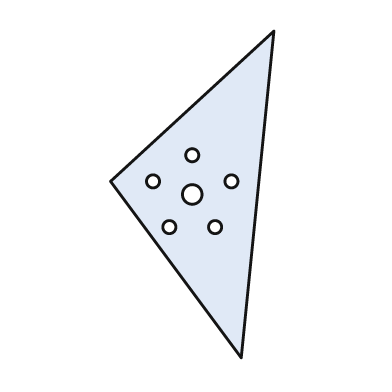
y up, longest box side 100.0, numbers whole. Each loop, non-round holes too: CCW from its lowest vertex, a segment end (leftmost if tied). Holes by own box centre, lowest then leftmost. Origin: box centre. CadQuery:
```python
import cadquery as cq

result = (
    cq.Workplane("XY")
    .moveTo(15.0, -50.0)
    .lineTo(25.0, 50.0)
    .lineTo(-25.0, 4.0)
    .close()
    .moveTo(-7.0, -10.0)
    .circle(2.0)
    .moveTo(7.0, -10.0)
    .circle(2.0)
    .moveTo(0.0, 0.0)
    .circle(3.0)
    .moveTo(-12.0, 4.0)
    .circle(2.0)
    .moveTo(12.0, 4.0)
    .circle(2.0)
    .moveTo(0.0, 12.0)
    .circle(2.0)
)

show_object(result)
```